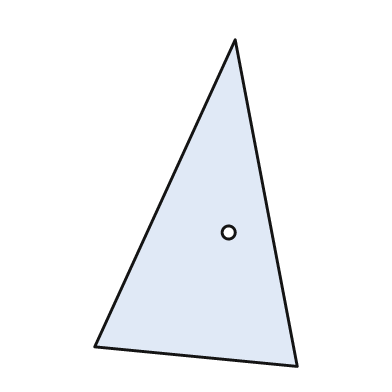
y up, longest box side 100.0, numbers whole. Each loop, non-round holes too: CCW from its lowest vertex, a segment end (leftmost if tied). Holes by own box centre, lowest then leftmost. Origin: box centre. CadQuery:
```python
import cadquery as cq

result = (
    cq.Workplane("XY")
    .moveTo(31.0, -50.0)
    .lineTo(12.0, 50.0)
    .lineTo(-31.0, -44.0)
    .close()
    .moveTo(10.0, -9.0)
    .circle(2.0)
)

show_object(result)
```